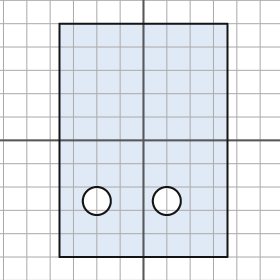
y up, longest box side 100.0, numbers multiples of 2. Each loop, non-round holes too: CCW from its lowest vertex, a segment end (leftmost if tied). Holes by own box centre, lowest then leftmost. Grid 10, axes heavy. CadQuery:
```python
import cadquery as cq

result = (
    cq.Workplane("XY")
    .moveTo(-36.0, -50.0)
    .lineTo(36.0, -50.0)
    .lineTo(36.0, 50.0)
    .lineTo(-36.0, 50.0)
    .close()
    .moveTo(-20.0, -26.0)
    .circle(6.0)
    .moveTo(10.0, -26.0)
    .circle(6.0)
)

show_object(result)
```